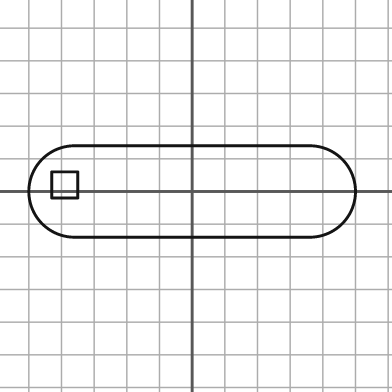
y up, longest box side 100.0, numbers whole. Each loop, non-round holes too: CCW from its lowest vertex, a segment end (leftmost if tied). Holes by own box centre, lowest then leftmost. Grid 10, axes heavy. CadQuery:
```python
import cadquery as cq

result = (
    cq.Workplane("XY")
    .moveTo(-36.0, -14.0)
    .lineTo(36.0, -14.0)
    .threePointArc((50.0, 0.0), (36.0, 14.0))
    .lineTo(-36.0, 14.0)
    .threePointArc((-50.0, 0.0), (-36.0, -14.0))
    .close()
    .moveTo(-43.0, -2.0)
    .lineTo(-35.0, -2.0)
    .lineTo(-35.0, 6.0)
    .lineTo(-43.0, 6.0)
    .close()
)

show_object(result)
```